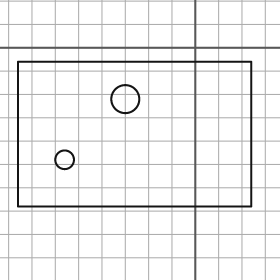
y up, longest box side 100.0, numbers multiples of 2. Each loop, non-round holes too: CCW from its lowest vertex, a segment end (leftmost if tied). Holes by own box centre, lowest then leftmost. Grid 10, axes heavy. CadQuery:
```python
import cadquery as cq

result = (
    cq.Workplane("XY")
    .moveTo(-76.0, -68.0)
    .lineTo(24.0, -68.0)
    .lineTo(24.0, -6.0)
    .lineTo(-76.0, -6.0)
    .close()
    .moveTo(-56.0, -48.0)
    .circle(4.0)
    .moveTo(-30.0, -22.0)
    .circle(6.0)
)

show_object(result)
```